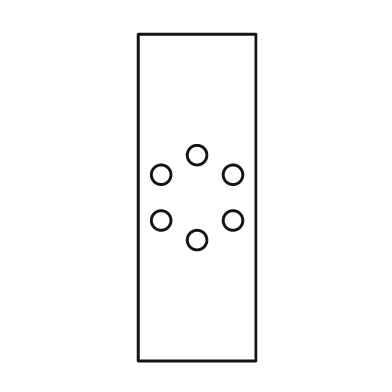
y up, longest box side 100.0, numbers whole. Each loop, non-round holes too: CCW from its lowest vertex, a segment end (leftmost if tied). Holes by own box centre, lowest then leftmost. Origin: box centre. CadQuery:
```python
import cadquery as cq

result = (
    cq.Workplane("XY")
    .moveTo(-18.0, -50.0)
    .lineTo(18.0, -50.0)
    .lineTo(18.0, 50.0)
    .lineTo(-18.0, 50.0)
    .close()
    .moveTo(0.0, -13.0)
    .circle(3.0)
    .moveTo(-11.0, -7.0)
    .circle(3.0)
    .moveTo(11.0, -7.0)
    .circle(3.0)
    .moveTo(-11.0, 7.0)
    .circle(3.0)
    .moveTo(11.0, 7.0)
    .circle(3.0)
    .moveTo(0.0, 13.0)
    .circle(3.0)
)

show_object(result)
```